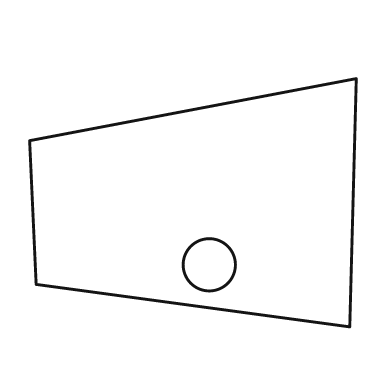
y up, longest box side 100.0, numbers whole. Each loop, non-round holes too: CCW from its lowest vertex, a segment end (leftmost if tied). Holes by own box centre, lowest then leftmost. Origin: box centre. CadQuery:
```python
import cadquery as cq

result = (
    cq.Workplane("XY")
    .moveTo(48.0, -38.0)
    .lineTo(50.0, 38.0)
    .lineTo(-50.0, 19.0)
    .lineTo(-48.0, -25.0)
    .close()
    .moveTo(5.0, -19.0)
    .circle(8.0)
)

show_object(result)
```